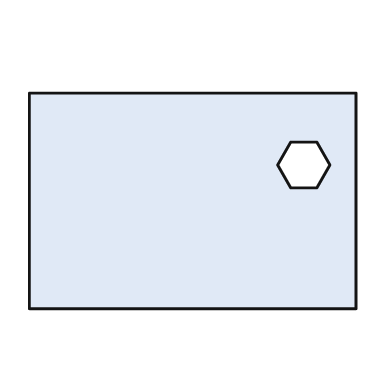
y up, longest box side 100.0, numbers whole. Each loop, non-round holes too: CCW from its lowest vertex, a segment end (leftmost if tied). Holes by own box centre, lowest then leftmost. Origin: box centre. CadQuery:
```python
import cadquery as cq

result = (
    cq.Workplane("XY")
    .moveTo(-50.0, -33.0)
    .lineTo(50.0, -33.0)
    .lineTo(50.0, 33.0)
    .lineTo(-50.0, 33.0)
    .close()
    .moveTo(30.0, 4.0)
    .lineTo(38.0, 4.0)
    .lineTo(42.0, 11.0)
    .lineTo(38.0, 18.0)
    .lineTo(30.0, 18.0)
    .lineTo(26.0, 11.0)
    .close()
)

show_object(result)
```